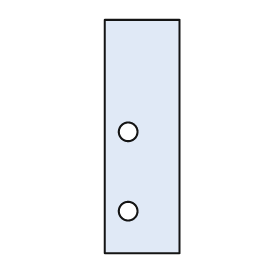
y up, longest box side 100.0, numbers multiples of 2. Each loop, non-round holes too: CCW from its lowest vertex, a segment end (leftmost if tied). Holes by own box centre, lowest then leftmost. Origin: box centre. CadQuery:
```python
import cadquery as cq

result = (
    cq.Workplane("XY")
    .moveTo(-16.0, -50.0)
    .lineTo(16.0, -50.0)
    .lineTo(16.0, 50.0)
    .lineTo(-16.0, 50.0)
    .close()
    .moveTo(-6.0, -32.0)
    .circle(4.0)
    .moveTo(-6.0, 2.0)
    .circle(4.0)
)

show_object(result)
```